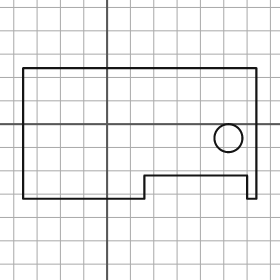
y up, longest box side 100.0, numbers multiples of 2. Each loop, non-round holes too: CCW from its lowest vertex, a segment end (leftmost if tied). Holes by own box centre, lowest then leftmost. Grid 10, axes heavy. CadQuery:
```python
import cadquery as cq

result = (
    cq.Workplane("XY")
    .moveTo(-36.0, -32.0)
    .lineTo(16.0, -32.0)
    .lineTo(16.0, -22.0)
    .lineTo(60.0, -22.0)
    .lineTo(60.0, -32.0)
    .lineTo(64.0, -32.0)
    .lineTo(64.0, 24.0)
    .lineTo(-36.0, 24.0)
    .close()
    .moveTo(52.0, -6.0)
    .circle(6.0)
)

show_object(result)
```